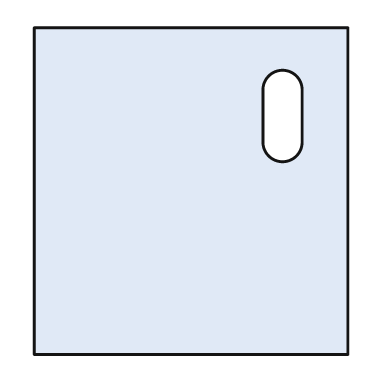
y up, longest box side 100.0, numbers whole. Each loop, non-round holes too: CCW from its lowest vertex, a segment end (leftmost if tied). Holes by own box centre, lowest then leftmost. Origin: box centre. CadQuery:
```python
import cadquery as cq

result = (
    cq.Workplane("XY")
    .moveTo(-48.0, -50.0)
    .lineTo(48.0, -50.0)
    .lineTo(48.0, 50.0)
    .lineTo(-48.0, 50.0)
    .close()
    .moveTo(22.0, 15.0)
    .threePointArc((28.0, 9.0), (34.0, 15.0))
    .lineTo(34.0, 31.0)
    .threePointArc((28.0, 37.0), (22.0, 31.0))
    .close()
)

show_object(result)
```